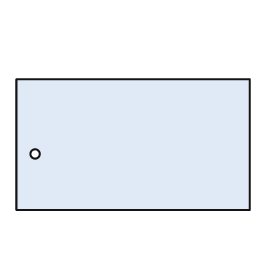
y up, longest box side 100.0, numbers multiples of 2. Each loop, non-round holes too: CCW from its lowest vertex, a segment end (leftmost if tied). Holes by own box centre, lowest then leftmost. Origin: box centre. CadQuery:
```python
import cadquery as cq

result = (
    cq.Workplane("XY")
    .moveTo(-50.0, -28.0)
    .lineTo(50.0, -28.0)
    .lineTo(50.0, 28.0)
    .lineTo(-50.0, 28.0)
    .close()
    .moveTo(-42.0, -4.0)
    .circle(2.0)
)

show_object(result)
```